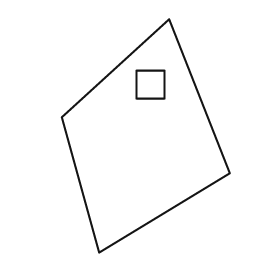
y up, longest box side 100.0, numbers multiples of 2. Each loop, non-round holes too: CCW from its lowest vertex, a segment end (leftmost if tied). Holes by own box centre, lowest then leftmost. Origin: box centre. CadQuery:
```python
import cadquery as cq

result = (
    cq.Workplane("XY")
    .moveTo(-20.0, -50.0)
    .lineTo(36.0, -16.0)
    .lineTo(10.0, 50.0)
    .lineTo(-36.0, 8.0)
    .close()
    .moveTo(-4.0, 16.0)
    .lineTo(8.0, 16.0)
    .lineTo(8.0, 28.0)
    .lineTo(-4.0, 28.0)
    .close()
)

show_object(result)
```